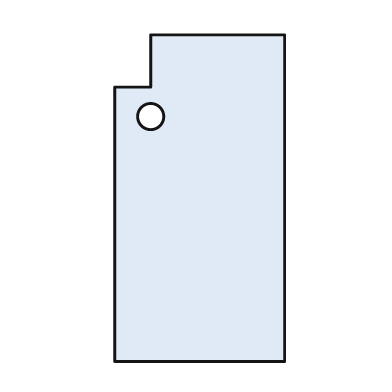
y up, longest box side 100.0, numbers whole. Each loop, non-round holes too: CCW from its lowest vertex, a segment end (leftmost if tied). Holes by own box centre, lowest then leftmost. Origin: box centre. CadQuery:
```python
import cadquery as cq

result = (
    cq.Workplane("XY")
    .moveTo(-26.0, -50.0)
    .lineTo(26.0, -50.0)
    .lineTo(26.0, 50.0)
    .lineTo(-15.0, 50.0)
    .lineTo(-15.0, 34.0)
    .lineTo(-26.0, 34.0)
    .close()
    .moveTo(-15.0, 25.0)
    .circle(4.0)
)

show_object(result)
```